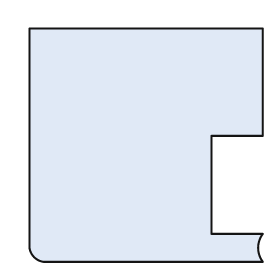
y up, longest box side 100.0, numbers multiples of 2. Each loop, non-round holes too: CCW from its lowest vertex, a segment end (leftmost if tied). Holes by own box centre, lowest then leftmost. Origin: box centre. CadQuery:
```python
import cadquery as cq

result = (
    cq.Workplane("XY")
    .moveTo(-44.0, -50.0)
    .lineTo(50.0, -50.0)
    .threePointArc((48.0, -44.0), (50.0, -38.0))
    .lineTo(28.0, -38.0)
    .lineTo(28.0, 4.0)
    .lineTo(50.0, 4.0)
    .lineTo(50.0, 50.0)
    .lineTo(-50.0, 50.0)
    .lineTo(-50.0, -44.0)
    .threePointArc((-48.0, -48.0), (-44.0, -50.0))
    .close()
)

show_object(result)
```